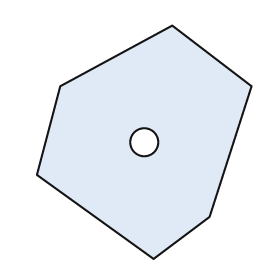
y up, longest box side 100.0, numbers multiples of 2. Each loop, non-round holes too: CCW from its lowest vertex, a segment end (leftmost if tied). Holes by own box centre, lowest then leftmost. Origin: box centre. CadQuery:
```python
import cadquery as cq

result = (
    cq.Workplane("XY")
    .moveTo(4.0, -50.0)
    .lineTo(28.0, -32.0)
    .lineTo(46.0, 24.0)
    .lineTo(12.0, 50.0)
    .lineTo(-36.0, 24.0)
    .lineTo(-46.0, -14.0)
    .close()
    .moveTo(0.0, 0.0)
    .circle(6.0)
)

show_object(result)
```